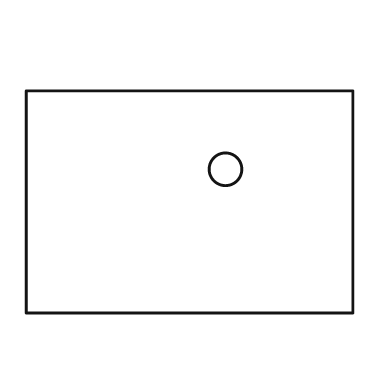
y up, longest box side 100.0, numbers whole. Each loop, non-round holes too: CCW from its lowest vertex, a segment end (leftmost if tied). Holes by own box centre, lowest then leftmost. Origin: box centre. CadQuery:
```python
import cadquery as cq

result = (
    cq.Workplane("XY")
    .moveTo(-50.0, -34.0)
    .lineTo(50.0, -34.0)
    .lineTo(50.0, 34.0)
    .lineTo(-50.0, 34.0)
    .close()
    .moveTo(11.0, 10.0)
    .circle(5.0)
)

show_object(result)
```